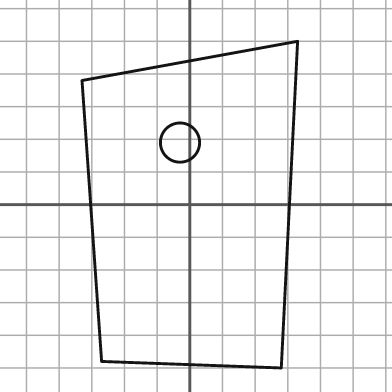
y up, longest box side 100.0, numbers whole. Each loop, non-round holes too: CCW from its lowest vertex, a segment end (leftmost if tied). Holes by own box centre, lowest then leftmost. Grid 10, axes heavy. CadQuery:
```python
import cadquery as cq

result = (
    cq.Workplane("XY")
    .moveTo(28.0, -50.0)
    .lineTo(33.0, 50.0)
    .lineTo(-33.0, 38.0)
    .lineTo(-27.0, -48.0)
    .close()
    .moveTo(-3.0, 19.0)
    .circle(6.0)
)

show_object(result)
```